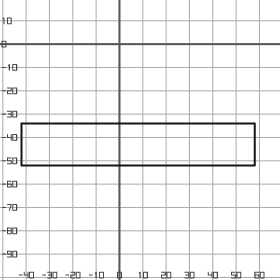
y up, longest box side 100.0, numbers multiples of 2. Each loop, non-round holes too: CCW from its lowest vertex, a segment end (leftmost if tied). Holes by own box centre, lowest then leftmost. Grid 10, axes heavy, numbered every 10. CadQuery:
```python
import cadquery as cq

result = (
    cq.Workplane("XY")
    .moveTo(-42.0, -52.0)
    .lineTo(58.0, -52.0)
    .lineTo(58.0, -34.0)
    .lineTo(-42.0, -34.0)
    .close()
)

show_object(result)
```